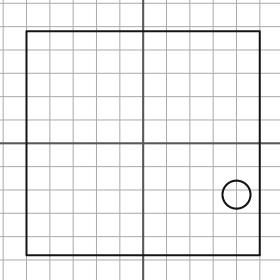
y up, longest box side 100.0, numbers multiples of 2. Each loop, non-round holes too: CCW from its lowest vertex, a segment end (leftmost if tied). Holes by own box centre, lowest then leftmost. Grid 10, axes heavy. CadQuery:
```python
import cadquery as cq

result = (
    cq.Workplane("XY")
    .moveTo(-50.0, -48.0)
    .lineTo(50.0, -48.0)
    .lineTo(50.0, 48.0)
    .lineTo(-50.0, 48.0)
    .close()
    .moveTo(40.0, -22.0)
    .circle(6.0)
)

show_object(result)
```